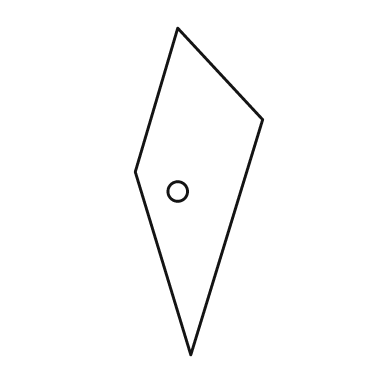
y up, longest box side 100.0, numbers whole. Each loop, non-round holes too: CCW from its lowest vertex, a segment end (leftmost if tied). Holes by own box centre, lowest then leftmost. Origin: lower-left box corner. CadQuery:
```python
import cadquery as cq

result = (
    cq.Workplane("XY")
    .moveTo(17.0, 0.0)
    .lineTo(39.0, 72.0)
    .lineTo(13.0, 100.0)
    .lineTo(0.0, 56.0)
    .close()
    .moveTo(13.0, 50.0)
    .circle(3.0)
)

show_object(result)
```